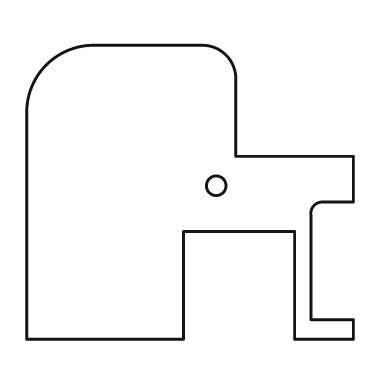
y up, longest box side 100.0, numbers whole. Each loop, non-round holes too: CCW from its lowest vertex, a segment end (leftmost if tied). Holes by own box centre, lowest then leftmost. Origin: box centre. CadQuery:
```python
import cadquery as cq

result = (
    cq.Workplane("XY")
    .moveTo(-50.0, -45.0)
    .lineTo(-2.0, -45.0)
    .lineTo(-2.0, -12.0)
    .lineTo(32.0, -12.0)
    .lineTo(32.0, -45.0)
    .lineTo(50.0, -45.0)
    .lineTo(50.0, -39.0)
    .lineTo(37.0, -39.0)
    .lineTo(37.0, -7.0)
    .threePointArc((38.0, -4.0), (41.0, -3.0))
    .lineTo(50.0, -3.0)
    .lineTo(50.0, 11.0)
    .lineTo(14.0, 11.0)
    .lineTo(14.0, 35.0)
    .threePointArc((11.0, 42.0), (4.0, 45.0))
    .lineTo(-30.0, 45.0)
    .threePointArc((-44.0, 39.0), (-50.0, 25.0))
    .close()
    .moveTo(8.0, 2.0)
    .circle(3.0)
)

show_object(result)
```